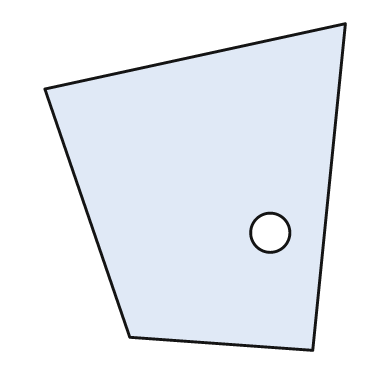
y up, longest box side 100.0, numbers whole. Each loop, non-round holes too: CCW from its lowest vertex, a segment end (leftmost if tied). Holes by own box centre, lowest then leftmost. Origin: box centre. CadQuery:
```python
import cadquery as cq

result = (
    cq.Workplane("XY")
    .moveTo(36.0, -50.0)
    .lineTo(46.0, 50.0)
    .lineTo(-46.0, 30.0)
    .lineTo(-20.0, -46.0)
    .close()
    .moveTo(23.0, -14.0)
    .circle(6.0)
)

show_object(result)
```